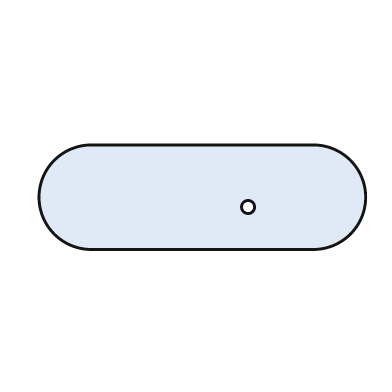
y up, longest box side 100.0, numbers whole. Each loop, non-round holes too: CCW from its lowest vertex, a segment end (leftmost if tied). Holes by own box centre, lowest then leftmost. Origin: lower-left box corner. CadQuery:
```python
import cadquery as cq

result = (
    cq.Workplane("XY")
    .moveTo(16.0, 0.0)
    .lineTo(84.0, 0.0)
    .threePointArc((100.0, 16.0), (84.0, 32.0))
    .lineTo(16.0, 32.0)
    .threePointArc((0.0, 16.0), (16.0, 0.0))
    .close()
    .moveTo(64.0, 13.0)
    .circle(2.0)
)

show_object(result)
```